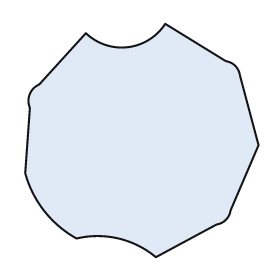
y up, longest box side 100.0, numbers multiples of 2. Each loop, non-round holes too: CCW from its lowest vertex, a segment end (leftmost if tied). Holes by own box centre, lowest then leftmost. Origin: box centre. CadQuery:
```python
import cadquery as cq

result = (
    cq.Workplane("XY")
    .moveTo(6.0, -50.0)
    .lineTo(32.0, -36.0)
    .threePointArc((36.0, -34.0), (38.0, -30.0))
    .lineTo(50.0, -2.0)
    .lineTo(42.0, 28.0)
    .threePointArc((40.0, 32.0), (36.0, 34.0))
    .lineTo(10.0, 50.0)
    .threePointArc((-6.0, 40.0), (-24.0, 46.0))
    .lineTo(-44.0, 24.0)
    .threePointArc((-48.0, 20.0), (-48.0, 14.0))
    .lineTo(-50.0, -14.0)
    .threePointArc((-42.0, -30.0), (-28.0, -42.0))
    .threePointArc((-10.0, -42.0), (6.0, -50.0))
    .close()
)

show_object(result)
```